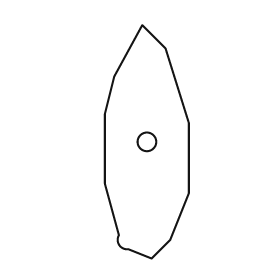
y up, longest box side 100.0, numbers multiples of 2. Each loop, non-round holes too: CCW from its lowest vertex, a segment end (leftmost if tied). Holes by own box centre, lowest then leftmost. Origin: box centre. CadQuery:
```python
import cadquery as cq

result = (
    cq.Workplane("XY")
    .moveTo(2.0, -50.0)
    .lineTo(10.0, -42.0)
    .lineTo(18.0, -22.0)
    .lineTo(18.0, 8.0)
    .lineTo(8.0, 40.0)
    .lineTo(-2.0, 50.0)
    .lineTo(-14.0, 28.0)
    .lineTo(-18.0, 12.0)
    .lineTo(-18.0, -18.0)
    .lineTo(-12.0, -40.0)
    .threePointArc((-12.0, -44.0), (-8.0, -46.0))
    .close()
    .moveTo(0.0, 0.0)
    .circle(4.0)
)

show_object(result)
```